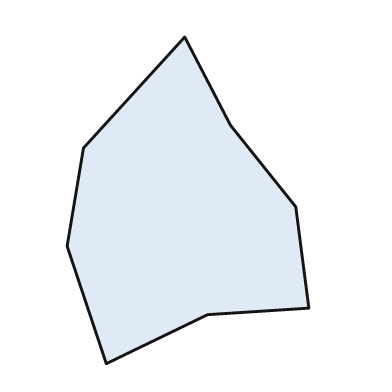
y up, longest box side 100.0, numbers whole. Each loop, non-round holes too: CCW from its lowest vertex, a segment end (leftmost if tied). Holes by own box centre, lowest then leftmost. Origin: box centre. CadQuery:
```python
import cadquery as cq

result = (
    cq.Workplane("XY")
    .moveTo(-25.0, -50.0)
    .lineTo(6.0, -35.0)
    .lineTo(37.0, -33.0)
    .lineTo(33.0, -2.0)
    .lineTo(13.0, 23.0)
    .lineTo(-1.0, 50.0)
    .lineTo(-32.0, 16.0)
    .lineTo(-37.0, -14.0)
    .close()
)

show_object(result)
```